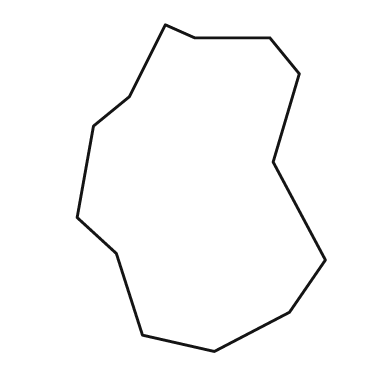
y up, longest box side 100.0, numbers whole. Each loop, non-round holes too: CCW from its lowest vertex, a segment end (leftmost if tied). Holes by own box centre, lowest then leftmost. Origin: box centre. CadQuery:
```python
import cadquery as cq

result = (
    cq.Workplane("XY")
    .moveTo(4.0, -50.0)
    .lineTo(27.0, -38.0)
    .lineTo(38.0, -22.0)
    .lineTo(22.0, 8.0)
    .lineTo(30.0, 35.0)
    .lineTo(21.0, 46.0)
    .lineTo(-2.0, 46.0)
    .lineTo(-11.0, 50.0)
    .lineTo(-22.0, 28.0)
    .lineTo(-33.0, 19.0)
    .lineTo(-38.0, -9.0)
    .lineTo(-26.0, -20.0)
    .lineTo(-18.0, -45.0)
    .close()
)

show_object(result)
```